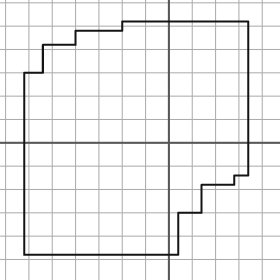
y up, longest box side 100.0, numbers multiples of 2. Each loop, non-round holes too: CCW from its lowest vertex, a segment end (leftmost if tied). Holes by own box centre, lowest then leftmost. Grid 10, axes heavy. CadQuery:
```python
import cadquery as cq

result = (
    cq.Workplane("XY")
    .moveTo(-62.0, -48.0)
    .lineTo(4.0, -48.0)
    .lineTo(4.0, -30.0)
    .lineTo(14.0, -30.0)
    .lineTo(14.0, -18.0)
    .lineTo(28.0, -18.0)
    .lineTo(28.0, -14.0)
    .lineTo(34.0, -14.0)
    .lineTo(34.0, 52.0)
    .lineTo(-20.0, 52.0)
    .lineTo(-20.0, 48.0)
    .lineTo(-40.0, 48.0)
    .lineTo(-40.0, 42.0)
    .lineTo(-54.0, 42.0)
    .lineTo(-54.0, 30.0)
    .lineTo(-62.0, 30.0)
    .close()
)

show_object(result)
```